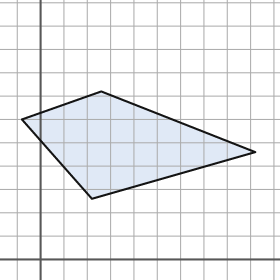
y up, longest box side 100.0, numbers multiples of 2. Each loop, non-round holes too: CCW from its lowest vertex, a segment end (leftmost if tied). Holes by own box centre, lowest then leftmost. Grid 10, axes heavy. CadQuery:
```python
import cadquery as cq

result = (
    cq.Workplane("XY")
    .moveTo(22.0, 26.0)
    .lineTo(92.0, 46.0)
    .lineTo(26.0, 72.0)
    .lineTo(-8.0, 60.0)
    .close()
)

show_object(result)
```